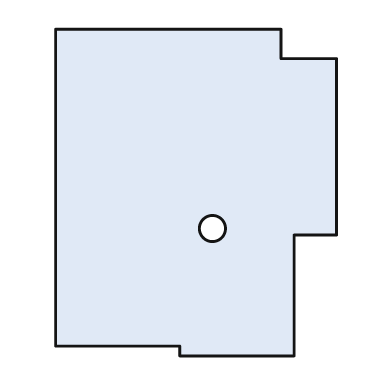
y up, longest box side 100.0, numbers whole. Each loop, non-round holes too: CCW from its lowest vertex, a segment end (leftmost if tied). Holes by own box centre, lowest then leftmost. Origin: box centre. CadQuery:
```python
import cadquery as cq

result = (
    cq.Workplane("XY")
    .moveTo(-5.0, -50.0)
    .lineTo(30.0, -50.0)
    .lineTo(30.0, -13.0)
    .lineTo(43.0, -13.0)
    .lineTo(43.0, 41.0)
    .lineTo(26.0, 41.0)
    .lineTo(26.0, 50.0)
    .lineTo(-43.0, 50.0)
    .lineTo(-43.0, -47.0)
    .lineTo(-5.0, -47.0)
    .close()
    .moveTo(5.0, -11.0)
    .circle(4.0)
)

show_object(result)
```